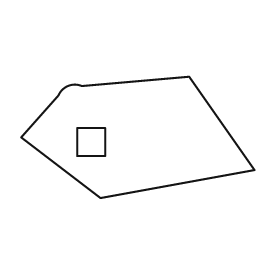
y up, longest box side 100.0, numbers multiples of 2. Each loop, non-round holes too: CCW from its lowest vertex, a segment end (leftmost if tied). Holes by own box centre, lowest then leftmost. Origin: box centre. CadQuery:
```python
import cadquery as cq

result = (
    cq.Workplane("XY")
    .moveTo(-16.0, -26.0)
    .lineTo(50.0, -14.0)
    .lineTo(22.0, 26.0)
    .lineTo(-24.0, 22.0)
    .threePointArc((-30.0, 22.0), (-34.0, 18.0))
    .lineTo(-50.0, 0.0)
    .close()
    .moveTo(-26.0, -8.0)
    .lineTo(-14.0, -8.0)
    .lineTo(-14.0, 4.0)
    .lineTo(-26.0, 4.0)
    .close()
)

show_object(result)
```